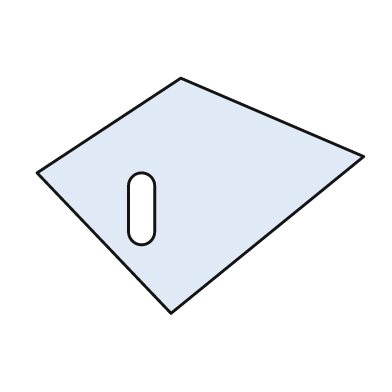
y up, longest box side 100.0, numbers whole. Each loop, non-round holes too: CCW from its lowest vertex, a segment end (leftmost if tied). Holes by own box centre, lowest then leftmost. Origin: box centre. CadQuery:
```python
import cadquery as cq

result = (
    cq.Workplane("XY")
    .moveTo(-9.0, -36.0)
    .lineTo(50.0, 12.0)
    .lineTo(-6.0, 36.0)
    .lineTo(-50.0, 7.0)
    .close()
    .moveTo(-22.0, -11.0)
    .threePointArc((-18.0, -15.0), (-14.0, -11.0))
    .lineTo(-14.0, 3.0)
    .threePointArc((-18.0, 7.0), (-22.0, 3.0))
    .close()
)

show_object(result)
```